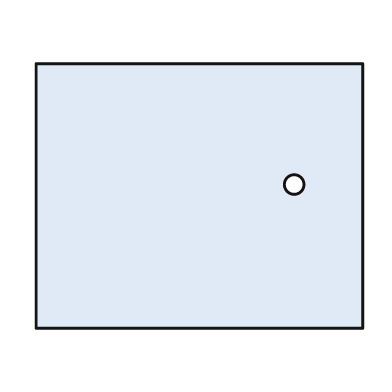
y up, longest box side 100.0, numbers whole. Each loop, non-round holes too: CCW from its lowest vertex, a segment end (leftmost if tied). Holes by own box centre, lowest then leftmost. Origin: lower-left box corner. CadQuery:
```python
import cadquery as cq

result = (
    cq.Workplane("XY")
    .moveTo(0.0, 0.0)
    .lineTo(100.0, 0.0)
    .lineTo(100.0, 81.0)
    .lineTo(0.0, 81.0)
    .close()
    .moveTo(79.0, 44.0)
    .circle(3.0)
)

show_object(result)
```